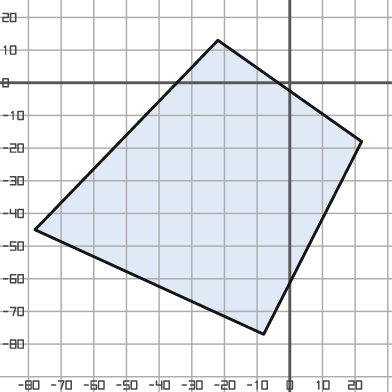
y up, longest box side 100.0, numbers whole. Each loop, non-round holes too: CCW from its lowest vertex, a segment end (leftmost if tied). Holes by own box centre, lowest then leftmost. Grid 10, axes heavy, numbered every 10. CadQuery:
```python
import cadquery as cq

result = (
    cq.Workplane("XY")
    .moveTo(-8.0, -77.0)
    .lineTo(22.0, -18.0)
    .lineTo(-22.0, 13.0)
    .lineTo(-78.0, -45.0)
    .close()
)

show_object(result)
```